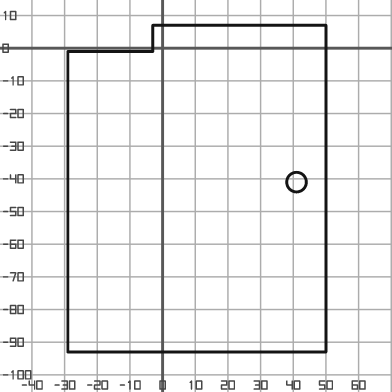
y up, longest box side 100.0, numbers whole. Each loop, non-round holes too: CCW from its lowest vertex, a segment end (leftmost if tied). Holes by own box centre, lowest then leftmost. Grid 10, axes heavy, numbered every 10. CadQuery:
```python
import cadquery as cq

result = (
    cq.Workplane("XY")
    .moveTo(-29.0, -93.0)
    .lineTo(50.0, -93.0)
    .lineTo(50.0, 7.0)
    .lineTo(-3.0, 7.0)
    .lineTo(-3.0, -1.0)
    .lineTo(-29.0, -1.0)
    .close()
    .moveTo(41.0, -41.0)
    .circle(3.0)
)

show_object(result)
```